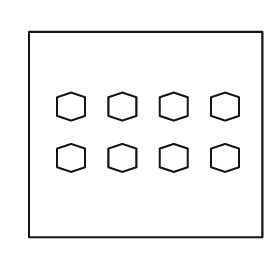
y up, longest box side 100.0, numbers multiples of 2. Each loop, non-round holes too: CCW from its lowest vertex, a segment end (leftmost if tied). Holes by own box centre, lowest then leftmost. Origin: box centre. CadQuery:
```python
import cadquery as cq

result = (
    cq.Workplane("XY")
    .moveTo(-50.0, -44.0)
    .lineTo(50.0, -44.0)
    .lineTo(50.0, 44.0)
    .lineTo(-50.0, 44.0)
    .close()
    .moveTo(-32.0, -16.0)
    .lineTo(-26.0, -14.0)
    .lineTo(-26.0, -6.0)
    .lineTo(-32.0, -4.0)
    .lineTo(-38.0, -6.0)
    .lineTo(-38.0, -14.0)
    .close()
    .moveTo(-10.0, -16.0)
    .lineTo(-4.0, -14.0)
    .lineTo(-4.0, -6.0)
    .lineTo(-10.0, -4.0)
    .lineTo(-16.0, -6.0)
    .lineTo(-16.0, -14.0)
    .close()
    .moveTo(12.0, -16.0)
    .lineTo(18.0, -14.0)
    .lineTo(18.0, -6.0)
    .lineTo(12.0, -4.0)
    .lineTo(6.0, -6.0)
    .lineTo(6.0, -14.0)
    .close()
    .moveTo(34.0, -16.0)
    .lineTo(40.0, -14.0)
    .lineTo(40.0, -6.0)
    .lineTo(34.0, -4.0)
    .lineTo(28.0, -6.0)
    .lineTo(28.0, -14.0)
    .close()
    .moveTo(-32.0, 6.0)
    .lineTo(-26.0, 8.0)
    .lineTo(-26.0, 16.0)
    .lineTo(-32.0, 18.0)
    .lineTo(-38.0, 16.0)
    .lineTo(-38.0, 8.0)
    .close()
    .moveTo(-10.0, 6.0)
    .lineTo(-4.0, 8.0)
    .lineTo(-4.0, 16.0)
    .lineTo(-10.0, 18.0)
    .lineTo(-16.0, 16.0)
    .lineTo(-16.0, 8.0)
    .close()
    .moveTo(12.0, 6.0)
    .lineTo(18.0, 8.0)
    .lineTo(18.0, 16.0)
    .lineTo(12.0, 18.0)
    .lineTo(6.0, 16.0)
    .lineTo(6.0, 8.0)
    .close()
    .moveTo(34.0, 6.0)
    .lineTo(40.0, 8.0)
    .lineTo(40.0, 16.0)
    .lineTo(34.0, 18.0)
    .lineTo(28.0, 16.0)
    .lineTo(28.0, 8.0)
    .close()
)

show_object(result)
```